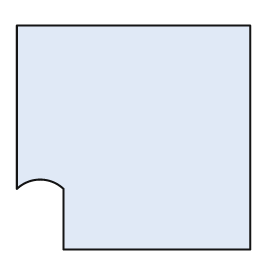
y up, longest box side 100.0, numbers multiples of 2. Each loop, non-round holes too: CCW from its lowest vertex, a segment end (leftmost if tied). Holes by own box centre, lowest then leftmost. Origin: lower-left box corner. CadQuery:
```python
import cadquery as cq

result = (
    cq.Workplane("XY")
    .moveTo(20.0, 0.0)
    .lineTo(100.0, 0.0)
    .lineTo(100.0, 96.0)
    .lineTo(0.0, 96.0)
    .lineTo(0.0, 26.0)
    .threePointArc((10.0, 30.0), (20.0, 26.0))
    .close()
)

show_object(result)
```